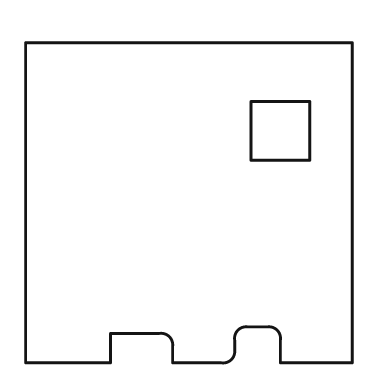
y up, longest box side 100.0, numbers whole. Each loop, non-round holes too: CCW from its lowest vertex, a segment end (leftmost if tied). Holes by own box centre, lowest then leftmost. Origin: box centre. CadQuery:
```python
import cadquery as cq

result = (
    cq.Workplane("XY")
    .moveTo(-50.0, -49.0)
    .lineTo(-24.0, -49.0)
    .lineTo(-24.0, -40.0)
    .lineTo(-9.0, -40.0)
    .threePointArc((-6.0, -41.0), (-5.0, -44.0))
    .lineTo(-5.0, -49.0)
    .lineTo(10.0, -49.0)
    .threePointArc((13.0, -48.0), (14.0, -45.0))
    .lineTo(14.0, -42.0)
    .threePointArc((15.0, -39.0), (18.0, -38.0))
    .lineTo(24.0, -38.0)
    .threePointArc((27.0, -39.0), (28.0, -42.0))
    .lineTo(28.0, -49.0)
    .lineTo(50.0, -49.0)
    .lineTo(50.0, 49.0)
    .lineTo(-50.0, 49.0)
    .close()
    .moveTo(19.0, 13.0)
    .lineTo(37.0, 13.0)
    .lineTo(37.0, 31.0)
    .lineTo(19.0, 31.0)
    .close()
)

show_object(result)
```